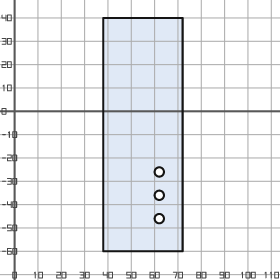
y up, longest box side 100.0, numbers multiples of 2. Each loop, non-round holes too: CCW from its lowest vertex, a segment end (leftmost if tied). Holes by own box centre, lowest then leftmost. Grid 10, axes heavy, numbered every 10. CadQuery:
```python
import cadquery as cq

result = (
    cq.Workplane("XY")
    .moveTo(38.0, -60.0)
    .lineTo(72.0, -60.0)
    .lineTo(72.0, 40.0)
    .lineTo(38.0, 40.0)
    .close()
    .moveTo(62.0, -46.0)
    .circle(2.0)
    .moveTo(62.0, -36.0)
    .circle(2.0)
    .moveTo(62.0, -26.0)
    .circle(2.0)
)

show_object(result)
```